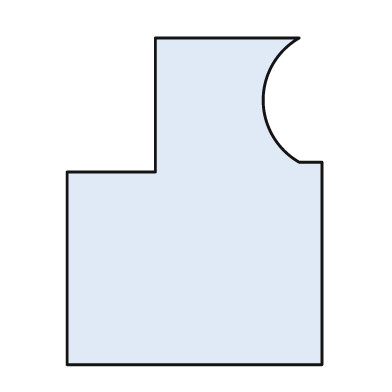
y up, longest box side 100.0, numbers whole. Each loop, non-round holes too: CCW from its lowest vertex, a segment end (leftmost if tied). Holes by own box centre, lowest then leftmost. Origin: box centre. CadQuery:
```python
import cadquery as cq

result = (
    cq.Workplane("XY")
    .moveTo(-39.0, -50.0)
    .lineTo(39.0, -50.0)
    .lineTo(39.0, 12.0)
    .lineTo(32.0, 12.0)
    .threePointArc((21.0, 31.0), (32.0, 50.0))
    .lineTo(-12.0, 50.0)
    .lineTo(-12.0, 9.0)
    .lineTo(-39.0, 9.0)
    .close()
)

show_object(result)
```